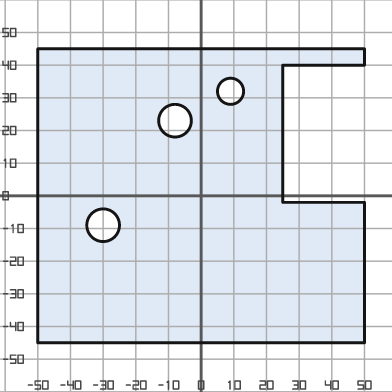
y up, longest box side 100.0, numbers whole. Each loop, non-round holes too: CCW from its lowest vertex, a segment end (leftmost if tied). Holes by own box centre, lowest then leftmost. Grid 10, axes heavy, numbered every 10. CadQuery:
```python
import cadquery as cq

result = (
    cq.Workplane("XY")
    .moveTo(-50.0, -45.0)
    .lineTo(50.0, -45.0)
    .lineTo(50.0, -2.0)
    .lineTo(25.0, -2.0)
    .lineTo(25.0, 40.0)
    .lineTo(50.0, 40.0)
    .lineTo(50.0, 45.0)
    .lineTo(-50.0, 45.0)
    .close()
    .moveTo(-30.0, -9.0)
    .circle(5.0)
    .moveTo(-8.0, 23.0)
    .circle(5.0)
    .moveTo(9.0, 32.0)
    .circle(4.0)
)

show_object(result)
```